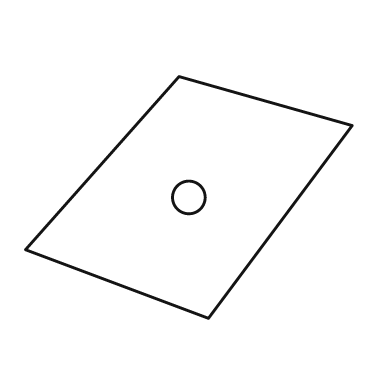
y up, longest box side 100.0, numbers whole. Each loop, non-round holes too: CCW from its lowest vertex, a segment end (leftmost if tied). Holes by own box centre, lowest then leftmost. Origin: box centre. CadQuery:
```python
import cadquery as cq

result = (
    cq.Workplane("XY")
    .moveTo(6.0, -37.0)
    .lineTo(50.0, 22.0)
    .lineTo(-3.0, 37.0)
    .lineTo(-50.0, -16.0)
    .close()
    .moveTo(0.0, 0.0)
    .circle(5.0)
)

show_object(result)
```